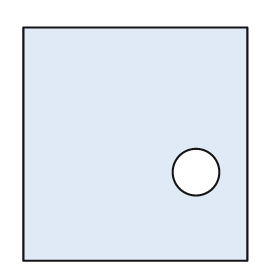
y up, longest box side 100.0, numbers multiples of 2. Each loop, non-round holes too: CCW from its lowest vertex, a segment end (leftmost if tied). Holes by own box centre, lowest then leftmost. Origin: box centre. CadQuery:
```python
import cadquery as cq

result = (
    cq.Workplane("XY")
    .moveTo(-48.0, -50.0)
    .lineTo(48.0, -50.0)
    .lineTo(48.0, 50.0)
    .lineTo(-48.0, 50.0)
    .close()
    .moveTo(26.0, -12.0)
    .circle(10.0)
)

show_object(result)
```